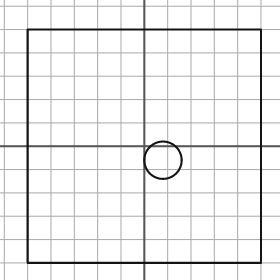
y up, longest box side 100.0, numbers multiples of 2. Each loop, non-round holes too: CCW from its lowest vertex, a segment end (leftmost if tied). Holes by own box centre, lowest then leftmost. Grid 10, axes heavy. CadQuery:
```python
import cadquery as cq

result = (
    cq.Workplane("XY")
    .moveTo(-50.0, -50.0)
    .lineTo(50.0, -50.0)
    .lineTo(50.0, 50.0)
    .lineTo(-50.0, 50.0)
    .close()
    .moveTo(8.0, -6.0)
    .circle(8.0)
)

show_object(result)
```